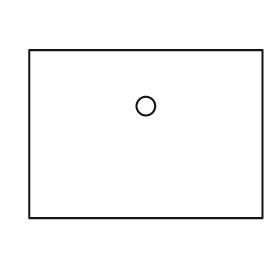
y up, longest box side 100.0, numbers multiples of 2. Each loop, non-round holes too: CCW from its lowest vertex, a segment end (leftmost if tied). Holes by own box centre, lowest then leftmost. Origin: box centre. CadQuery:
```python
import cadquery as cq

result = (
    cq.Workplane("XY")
    .moveTo(-50.0, -36.0)
    .lineTo(50.0, -36.0)
    .lineTo(50.0, 36.0)
    .lineTo(-50.0, 36.0)
    .close()
    .moveTo(0.0, 12.0)
    .circle(4.0)
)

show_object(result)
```